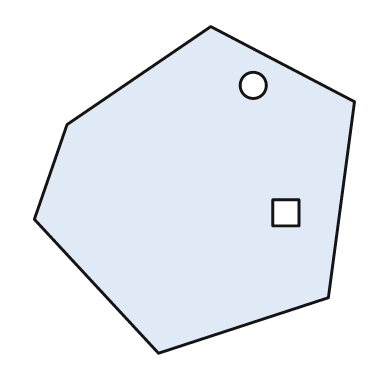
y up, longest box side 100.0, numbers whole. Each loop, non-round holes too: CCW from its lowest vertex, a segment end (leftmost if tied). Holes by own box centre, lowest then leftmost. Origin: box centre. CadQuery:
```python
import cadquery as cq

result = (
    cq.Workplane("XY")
    .moveTo(-11.0, -50.0)
    .lineTo(41.0, -33.0)
    .lineTo(49.0, 27.0)
    .lineTo(5.0, 50.0)
    .lineTo(-39.0, 20.0)
    .lineTo(-49.0, -9.0)
    .close()
    .moveTo(24.0, -11.0)
    .lineTo(32.0, -11.0)
    .lineTo(32.0, -3.0)
    .lineTo(24.0, -3.0)
    .close()
    .moveTo(18.0, 32.0)
    .circle(4.0)
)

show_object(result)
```